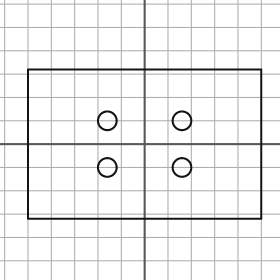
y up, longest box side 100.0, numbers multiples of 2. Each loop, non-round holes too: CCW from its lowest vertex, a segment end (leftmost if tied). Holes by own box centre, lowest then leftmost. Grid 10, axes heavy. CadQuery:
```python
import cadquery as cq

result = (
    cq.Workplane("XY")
    .moveTo(-50.0, -32.0)
    .lineTo(50.0, -32.0)
    .lineTo(50.0, 32.0)
    .lineTo(-50.0, 32.0)
    .close()
    .moveTo(-16.0, -10.0)
    .circle(4.0)
    .moveTo(16.0, -10.0)
    .circle(4.0)
    .moveTo(-16.0, 10.0)
    .circle(4.0)
    .moveTo(16.0, 10.0)
    .circle(4.0)
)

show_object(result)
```